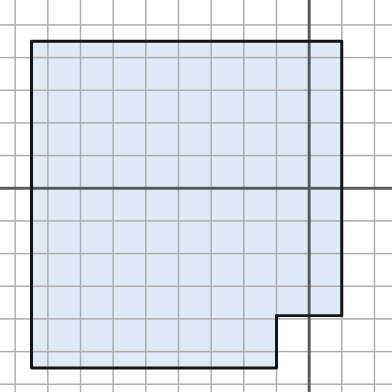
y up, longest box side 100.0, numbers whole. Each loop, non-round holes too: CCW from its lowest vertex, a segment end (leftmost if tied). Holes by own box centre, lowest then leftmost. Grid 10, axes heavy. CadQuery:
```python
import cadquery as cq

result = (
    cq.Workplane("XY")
    .moveTo(-85.0, -55.0)
    .lineTo(-10.0, -55.0)
    .lineTo(-10.0, -39.0)
    .lineTo(10.0, -39.0)
    .lineTo(10.0, 45.0)
    .lineTo(-85.0, 45.0)
    .close()
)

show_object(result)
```